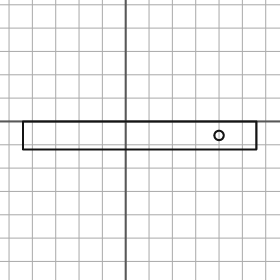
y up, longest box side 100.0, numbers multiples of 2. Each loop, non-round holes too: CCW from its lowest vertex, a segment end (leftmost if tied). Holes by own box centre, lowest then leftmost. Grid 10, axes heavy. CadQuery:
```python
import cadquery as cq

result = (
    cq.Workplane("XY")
    .moveTo(-44.0, -12.0)
    .lineTo(56.0, -12.0)
    .lineTo(56.0, 0.0)
    .lineTo(-44.0, 0.0)
    .close()
    .moveTo(40.0, -6.0)
    .circle(2.0)
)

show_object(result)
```